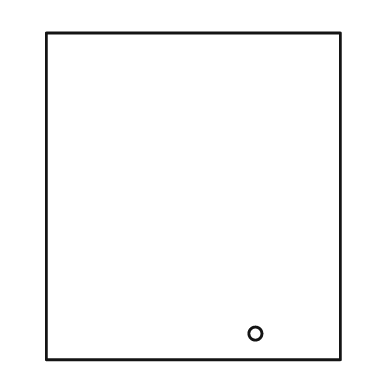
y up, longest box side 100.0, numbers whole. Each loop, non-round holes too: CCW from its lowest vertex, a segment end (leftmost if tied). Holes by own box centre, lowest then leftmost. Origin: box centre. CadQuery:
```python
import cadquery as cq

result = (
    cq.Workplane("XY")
    .moveTo(-45.0, -50.0)
    .lineTo(45.0, -50.0)
    .lineTo(45.0, 50.0)
    .lineTo(-45.0, 50.0)
    .close()
    .moveTo(19.0, -42.0)
    .circle(2.0)
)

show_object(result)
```